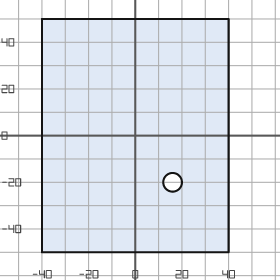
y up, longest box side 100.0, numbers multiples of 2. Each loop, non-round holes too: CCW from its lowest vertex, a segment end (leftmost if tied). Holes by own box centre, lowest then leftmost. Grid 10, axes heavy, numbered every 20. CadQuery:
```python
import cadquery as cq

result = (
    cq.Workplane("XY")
    .moveTo(-40.0, -50.0)
    .lineTo(40.0, -50.0)
    .lineTo(40.0, 50.0)
    .lineTo(-40.0, 50.0)
    .close()
    .moveTo(16.0, -20.0)
    .circle(4.0)
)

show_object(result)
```